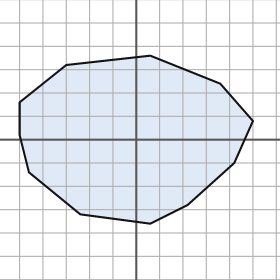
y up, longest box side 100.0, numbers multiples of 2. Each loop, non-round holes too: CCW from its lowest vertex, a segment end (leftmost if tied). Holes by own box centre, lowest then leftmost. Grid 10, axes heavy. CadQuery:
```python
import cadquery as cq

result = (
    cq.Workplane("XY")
    .moveTo(6.0, -36.0)
    .lineTo(22.0, -28.0)
    .lineTo(42.0, -10.0)
    .lineTo(50.0, 8.0)
    .lineTo(36.0, 24.0)
    .lineTo(6.0, 36.0)
    .lineTo(-30.0, 32.0)
    .lineTo(-50.0, 16.0)
    .lineTo(-50.0, 2.0)
    .lineTo(-46.0, -14.0)
    .lineTo(-24.0, -32.0)
    .close()
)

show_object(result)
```